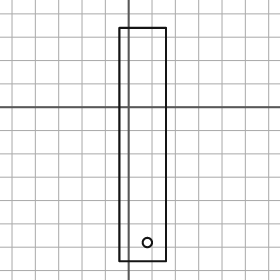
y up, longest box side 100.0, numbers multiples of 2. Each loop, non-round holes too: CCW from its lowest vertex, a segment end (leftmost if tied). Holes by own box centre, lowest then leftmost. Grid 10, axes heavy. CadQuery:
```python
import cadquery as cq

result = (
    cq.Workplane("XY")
    .moveTo(-4.0, -66.0)
    .lineTo(16.0, -66.0)
    .lineTo(16.0, 34.0)
    .lineTo(-4.0, 34.0)
    .close()
    .moveTo(8.0, -58.0)
    .circle(2.0)
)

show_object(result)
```